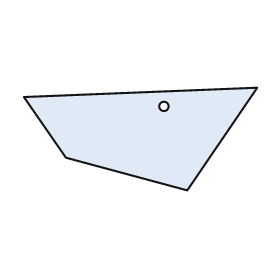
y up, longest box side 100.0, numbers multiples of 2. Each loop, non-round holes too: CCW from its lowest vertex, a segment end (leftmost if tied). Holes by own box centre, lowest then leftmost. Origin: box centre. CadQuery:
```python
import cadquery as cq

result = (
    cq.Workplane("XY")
    .moveTo(20.0, -22.0)
    .lineTo(50.0, 22.0)
    .lineTo(-50.0, 18.0)
    .lineTo(-32.0, -8.0)
    .close()
    .moveTo(10.0, 14.0)
    .circle(2.0)
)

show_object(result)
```